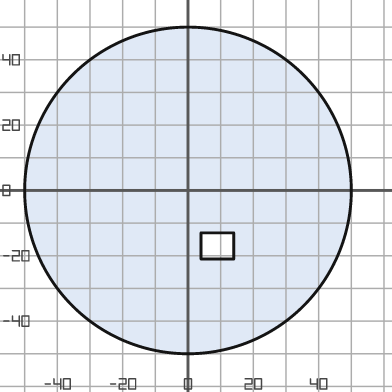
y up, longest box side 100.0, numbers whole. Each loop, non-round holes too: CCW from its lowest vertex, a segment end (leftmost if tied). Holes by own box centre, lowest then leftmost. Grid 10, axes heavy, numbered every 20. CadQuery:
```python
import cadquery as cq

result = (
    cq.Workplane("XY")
    .moveTo(0.0, 0.0)
    .circle(50.0)
    .moveTo(4.0, -21.0)
    .lineTo(14.0, -21.0)
    .lineTo(14.0, -13.0)
    .lineTo(4.0, -13.0)
    .close()
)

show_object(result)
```